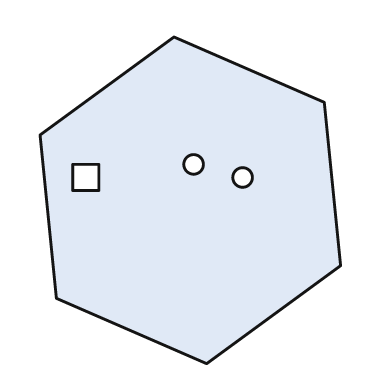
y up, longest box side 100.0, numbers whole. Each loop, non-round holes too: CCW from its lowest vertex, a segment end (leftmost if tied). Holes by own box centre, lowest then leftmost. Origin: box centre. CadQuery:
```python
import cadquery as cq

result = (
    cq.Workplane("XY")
    .moveTo(5.0, -50.0)
    .lineTo(46.0, -20.0)
    .lineTo(41.0, 30.0)
    .lineTo(-5.0, 50.0)
    .lineTo(-46.0, 20.0)
    .lineTo(-41.0, -30.0)
    .close()
    .moveTo(-36.0, 3.0)
    .lineTo(-28.0, 3.0)
    .lineTo(-28.0, 11.0)
    .lineTo(-36.0, 11.0)
    .close()
    .moveTo(16.0, 7.0)
    .circle(3.0)
    .moveTo(1.0, 11.0)
    .circle(3.0)
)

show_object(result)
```